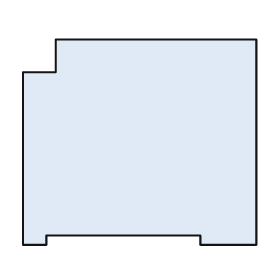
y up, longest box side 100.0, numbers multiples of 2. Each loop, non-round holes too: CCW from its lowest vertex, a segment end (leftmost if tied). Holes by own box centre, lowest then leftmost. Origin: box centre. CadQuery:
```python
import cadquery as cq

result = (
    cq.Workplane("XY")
    .moveTo(-50.0, -44.0)
    .lineTo(-40.0, -44.0)
    .lineTo(-40.0, -40.0)
    .lineTo(26.0, -40.0)
    .lineTo(26.0, -44.0)
    .lineTo(50.0, -44.0)
    .lineTo(50.0, 44.0)
    .lineTo(-36.0, 44.0)
    .lineTo(-36.0, 30.0)
    .lineTo(-50.0, 30.0)
    .close()
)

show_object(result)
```